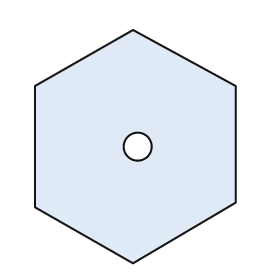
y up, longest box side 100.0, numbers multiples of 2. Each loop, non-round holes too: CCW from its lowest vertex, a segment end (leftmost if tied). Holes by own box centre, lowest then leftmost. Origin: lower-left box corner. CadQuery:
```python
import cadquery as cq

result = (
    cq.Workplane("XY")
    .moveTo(42.0, 0.0)
    .lineTo(86.0, 26.0)
    .lineTo(86.0, 76.0)
    .lineTo(42.0, 100.0)
    .lineTo(0.0, 76.0)
    .lineTo(0.0, 24.0)
    .close()
    .moveTo(44.0, 50.0)
    .circle(6.0)
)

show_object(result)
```